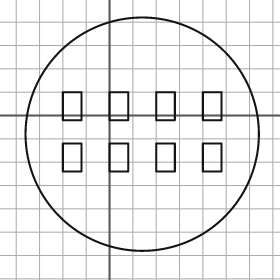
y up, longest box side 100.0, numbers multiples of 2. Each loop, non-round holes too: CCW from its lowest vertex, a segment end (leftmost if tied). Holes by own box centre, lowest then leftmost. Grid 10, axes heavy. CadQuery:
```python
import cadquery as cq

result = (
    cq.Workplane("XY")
    .moveTo(14.0, -8.0)
    .circle(50.0)
    .moveTo(-20.0, -24.0)
    .lineTo(-12.0, -24.0)
    .lineTo(-12.0, -12.0)
    .lineTo(-20.0, -12.0)
    .close()
    .moveTo(0.0, -24.0)
    .lineTo(8.0, -24.0)
    .lineTo(8.0, -12.0)
    .lineTo(0.0, -12.0)
    .close()
    .moveTo(20.0, -24.0)
    .lineTo(28.0, -24.0)
    .lineTo(28.0, -12.0)
    .lineTo(20.0, -12.0)
    .close()
    .moveTo(40.0, -24.0)
    .lineTo(48.0, -24.0)
    .lineTo(48.0, -12.0)
    .lineTo(40.0, -12.0)
    .close()
    .moveTo(-20.0, -2.0)
    .lineTo(-12.0, -2.0)
    .lineTo(-12.0, 10.0)
    .lineTo(-20.0, 10.0)
    .close()
    .moveTo(0.0, -2.0)
    .lineTo(8.0, -2.0)
    .lineTo(8.0, 10.0)
    .lineTo(0.0, 10.0)
    .close()
    .moveTo(20.0, -2.0)
    .lineTo(28.0, -2.0)
    .lineTo(28.0, 10.0)
    .lineTo(20.0, 10.0)
    .close()
    .moveTo(40.0, -2.0)
    .lineTo(48.0, -2.0)
    .lineTo(48.0, 10.0)
    .lineTo(40.0, 10.0)
    .close()
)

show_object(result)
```